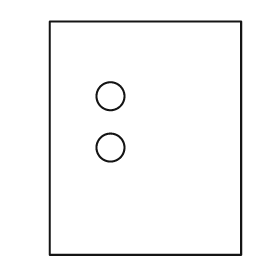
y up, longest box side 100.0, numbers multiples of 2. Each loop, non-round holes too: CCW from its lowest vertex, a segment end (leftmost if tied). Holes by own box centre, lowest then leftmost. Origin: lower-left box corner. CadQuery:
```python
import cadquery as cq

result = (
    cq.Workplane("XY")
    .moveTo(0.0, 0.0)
    .lineTo(82.0, 0.0)
    .lineTo(82.0, 100.0)
    .lineTo(0.0, 100.0)
    .close()
    .moveTo(26.0, 46.0)
    .circle(6.0)
    .moveTo(26.0, 68.0)
    .circle(6.0)
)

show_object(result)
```